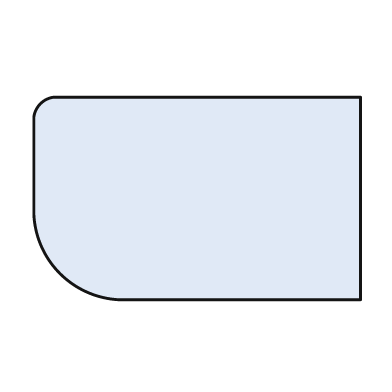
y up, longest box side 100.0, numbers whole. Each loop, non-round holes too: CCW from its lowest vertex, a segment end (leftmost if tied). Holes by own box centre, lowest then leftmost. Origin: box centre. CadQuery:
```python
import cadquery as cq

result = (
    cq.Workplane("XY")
    .moveTo(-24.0, -31.0)
    .lineTo(50.0, -31.0)
    .lineTo(50.0, 31.0)
    .lineTo(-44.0, 31.0)
    .threePointArc((-48.0, 29.0), (-50.0, 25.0))
    .lineTo(-50.0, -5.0)
    .threePointArc((-42.0, -23.0), (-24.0, -31.0))
    .close()
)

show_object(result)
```